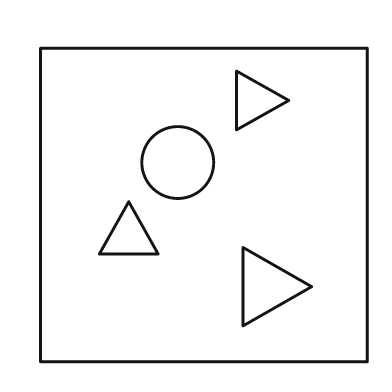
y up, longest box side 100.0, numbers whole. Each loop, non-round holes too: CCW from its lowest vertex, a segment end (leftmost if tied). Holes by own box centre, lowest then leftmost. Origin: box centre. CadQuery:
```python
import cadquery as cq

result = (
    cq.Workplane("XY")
    .moveTo(-50.0, -48.0)
    .lineTo(50.0, -48.0)
    .lineTo(50.0, 48.0)
    .lineTo(-50.0, 48.0)
    .close()
    .moveTo(12.0, -37.0)
    .lineTo(33.0, -25.0)
    .lineTo(12.0, -13.0)
    .close()
    .moveTo(-32.0, -15.0)
    .lineTo(-14.0, -15.0)
    .lineTo(-23.0, 1.0)
    .close()
    .moveTo(-8.0, 13.0)
    .circle(11.0)
    .moveTo(10.0, 23.0)
    .lineTo(26.0, 32.0)
    .lineTo(10.0, 41.0)
    .close()
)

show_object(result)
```